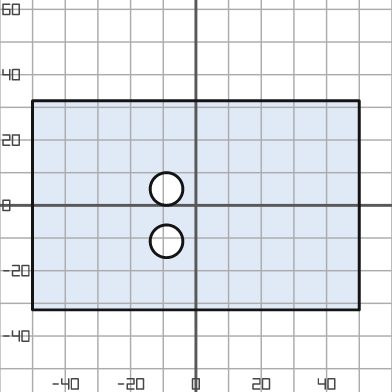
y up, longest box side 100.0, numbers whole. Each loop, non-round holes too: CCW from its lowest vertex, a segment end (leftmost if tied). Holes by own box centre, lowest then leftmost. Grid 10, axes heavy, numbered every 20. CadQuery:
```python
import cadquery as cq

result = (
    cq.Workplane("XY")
    .moveTo(-50.0, -32.0)
    .lineTo(50.0, -32.0)
    .lineTo(50.0, 32.0)
    .lineTo(-50.0, 32.0)
    .close()
    .moveTo(-9.0, -11.0)
    .circle(5.0)
    .moveTo(-9.0, 5.0)
    .circle(5.0)
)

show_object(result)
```